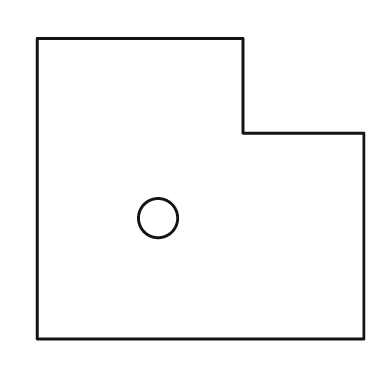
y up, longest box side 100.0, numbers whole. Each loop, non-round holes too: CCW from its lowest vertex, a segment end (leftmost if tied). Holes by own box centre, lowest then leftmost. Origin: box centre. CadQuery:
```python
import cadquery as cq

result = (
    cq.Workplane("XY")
    .moveTo(-50.0, -46.0)
    .lineTo(50.0, -46.0)
    .lineTo(50.0, 17.0)
    .lineTo(13.0, 17.0)
    .lineTo(13.0, 46.0)
    .lineTo(-50.0, 46.0)
    .close()
    .moveTo(-13.0, -9.0)
    .circle(6.0)
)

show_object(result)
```